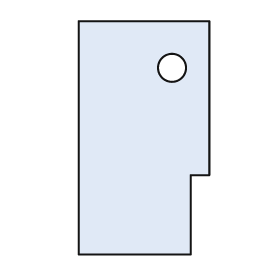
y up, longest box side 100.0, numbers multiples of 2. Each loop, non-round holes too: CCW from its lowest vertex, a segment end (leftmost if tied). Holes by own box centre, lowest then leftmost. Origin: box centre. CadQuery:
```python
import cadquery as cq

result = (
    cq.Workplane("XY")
    .moveTo(-28.0, -50.0)
    .lineTo(20.0, -50.0)
    .lineTo(20.0, -16.0)
    .lineTo(28.0, -16.0)
    .lineTo(28.0, 50.0)
    .lineTo(-28.0, 50.0)
    .close()
    .moveTo(12.0, 30.0)
    .circle(6.0)
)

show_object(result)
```